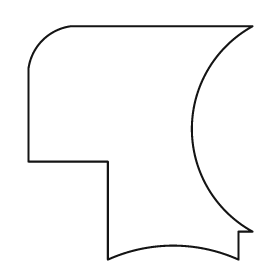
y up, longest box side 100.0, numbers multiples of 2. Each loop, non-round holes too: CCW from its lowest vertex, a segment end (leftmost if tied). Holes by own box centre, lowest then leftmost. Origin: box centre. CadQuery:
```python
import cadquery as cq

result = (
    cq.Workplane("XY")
    .moveTo(-14.0, -50.0)
    .threePointArc((14.0, -44.0), (42.0, -50.0))
    .lineTo(42.0, -38.0)
    .lineTo(48.0, -38.0)
    .threePointArc((22.0, 6.0), (48.0, 50.0))
    .lineTo(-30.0, 50.0)
    .threePointArc((-42.0, 44.0), (-48.0, 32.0))
    .lineTo(-48.0, -8.0)
    .lineTo(-14.0, -8.0)
    .close()
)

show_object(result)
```